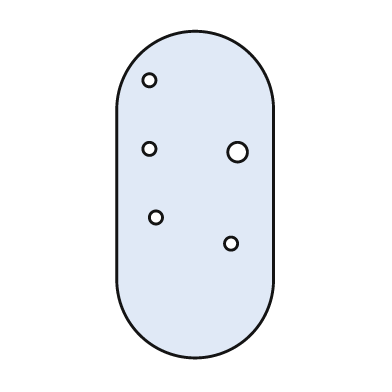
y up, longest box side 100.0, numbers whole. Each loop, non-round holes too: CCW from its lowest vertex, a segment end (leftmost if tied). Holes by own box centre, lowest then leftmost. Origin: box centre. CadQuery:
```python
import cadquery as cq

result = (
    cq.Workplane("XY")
    .moveTo(-24.0, -26.0)
    .threePointArc((0.0, -50.0), (24.0, -26.0))
    .lineTo(24.0, 26.0)
    .threePointArc((0.0, 50.0), (-24.0, 26.0))
    .close()
    .moveTo(11.0, -15.0)
    .circle(2.0)
    .moveTo(-12.0, -7.0)
    .circle(2.0)
    .moveTo(13.0, 13.0)
    .circle(3.0)
    .moveTo(-14.0, 14.0)
    .circle(2.0)
    .moveTo(-14.0, 35.0)
    .circle(2.0)
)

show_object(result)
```